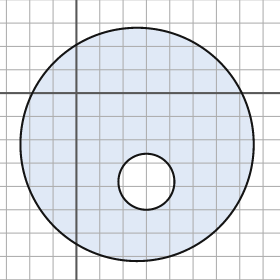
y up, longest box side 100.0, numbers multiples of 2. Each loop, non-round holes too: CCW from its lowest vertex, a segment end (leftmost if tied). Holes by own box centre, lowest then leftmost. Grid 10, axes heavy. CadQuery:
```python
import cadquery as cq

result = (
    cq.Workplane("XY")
    .moveTo(26.0, -22.0)
    .circle(50.0)
    .moveTo(30.0, -38.0)
    .circle(12.0)
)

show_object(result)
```